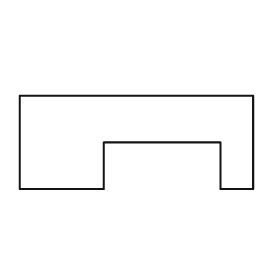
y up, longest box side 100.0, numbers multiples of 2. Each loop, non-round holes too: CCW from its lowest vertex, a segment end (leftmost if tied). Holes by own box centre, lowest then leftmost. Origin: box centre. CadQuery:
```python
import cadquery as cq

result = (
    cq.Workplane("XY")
    .moveTo(-50.0, -20.0)
    .lineTo(-14.0, -20.0)
    .lineTo(-14.0, 0.0)
    .lineTo(36.0, 0.0)
    .lineTo(36.0, -20.0)
    .lineTo(50.0, -20.0)
    .lineTo(50.0, 20.0)
    .lineTo(-50.0, 20.0)
    .close()
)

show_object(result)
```